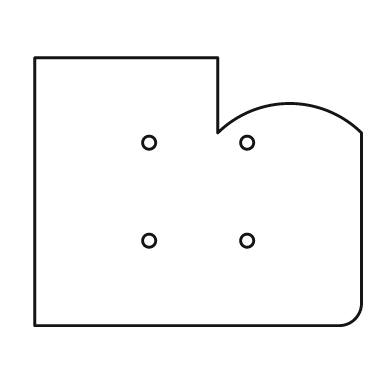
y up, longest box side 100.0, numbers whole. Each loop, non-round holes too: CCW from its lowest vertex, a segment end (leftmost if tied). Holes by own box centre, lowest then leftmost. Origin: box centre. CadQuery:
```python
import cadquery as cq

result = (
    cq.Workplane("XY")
    .moveTo(-50.0, -41.0)
    .lineTo(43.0, -41.0)
    .threePointArc((48.0, -39.0), (50.0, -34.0))
    .lineTo(50.0, 18.0)
    .threePointArc((28.0, 27.0), (6.0, 18.0))
    .lineTo(6.0, 41.0)
    .lineTo(-50.0, 41.0)
    .close()
    .moveTo(-15.0, -15.0)
    .circle(2.0)
    .moveTo(15.0, -15.0)
    .circle(2.0)
    .moveTo(-15.0, 15.0)
    .circle(2.0)
    .moveTo(15.0, 15.0)
    .circle(2.0)
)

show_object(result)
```